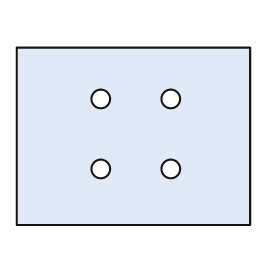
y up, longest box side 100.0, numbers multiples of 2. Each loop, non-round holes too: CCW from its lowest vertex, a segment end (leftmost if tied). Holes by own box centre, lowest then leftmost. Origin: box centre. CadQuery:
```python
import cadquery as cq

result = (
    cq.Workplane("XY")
    .moveTo(-50.0, -38.0)
    .lineTo(50.0, -38.0)
    .lineTo(50.0, 38.0)
    .lineTo(-50.0, 38.0)
    .close()
    .moveTo(-14.0, -14.0)
    .circle(4.0)
    .moveTo(16.0, -14.0)
    .circle(4.0)
    .moveTo(-14.0, 16.0)
    .circle(4.0)
    .moveTo(16.0, 16.0)
    .circle(4.0)
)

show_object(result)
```